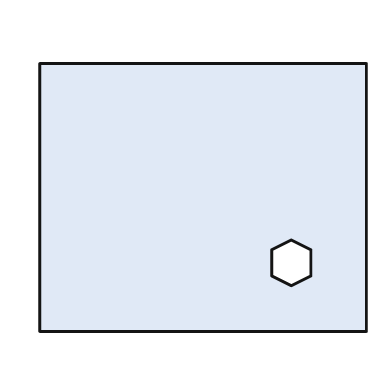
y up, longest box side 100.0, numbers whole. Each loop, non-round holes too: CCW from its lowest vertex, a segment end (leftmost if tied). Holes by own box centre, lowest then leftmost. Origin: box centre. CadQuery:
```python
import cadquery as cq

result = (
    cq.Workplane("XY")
    .moveTo(-50.0, -41.0)
    .lineTo(50.0, -41.0)
    .lineTo(50.0, 41.0)
    .lineTo(-50.0, 41.0)
    .close()
    .moveTo(27.0, -27.0)
    .lineTo(33.0, -24.0)
    .lineTo(33.0, -16.0)
    .lineTo(27.0, -13.0)
    .lineTo(21.0, -16.0)
    .lineTo(21.0, -24.0)
    .close()
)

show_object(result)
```